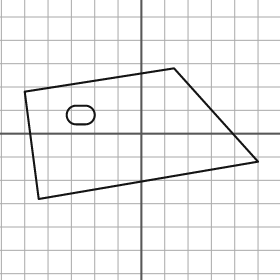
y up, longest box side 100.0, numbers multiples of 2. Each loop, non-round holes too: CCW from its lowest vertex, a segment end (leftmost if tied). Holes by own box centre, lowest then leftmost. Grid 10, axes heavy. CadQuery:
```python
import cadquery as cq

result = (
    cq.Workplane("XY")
    .moveTo(-44.0, -28.0)
    .lineTo(50.0, -12.0)
    .lineTo(14.0, 28.0)
    .lineTo(-50.0, 18.0)
    .close()
    .moveTo(-28.0, 4.0)
    .lineTo(-24.0, 4.0)
    .threePointArc((-20.0, 8.0), (-24.0, 12.0))
    .lineTo(-28.0, 12.0)
    .threePointArc((-32.0, 8.0), (-28.0, 4.0))
    .close()
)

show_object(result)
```